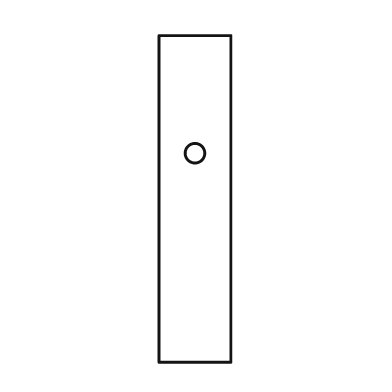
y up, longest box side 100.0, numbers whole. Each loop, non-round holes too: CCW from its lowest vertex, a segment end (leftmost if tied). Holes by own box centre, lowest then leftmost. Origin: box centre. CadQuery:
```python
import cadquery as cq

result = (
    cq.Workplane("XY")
    .moveTo(-11.0, -50.0)
    .lineTo(11.0, -50.0)
    .lineTo(11.0, 50.0)
    .lineTo(-11.0, 50.0)
    .close()
    .moveTo(0.0, 14.0)
    .circle(3.0)
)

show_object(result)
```